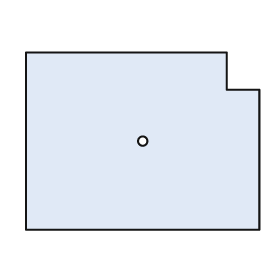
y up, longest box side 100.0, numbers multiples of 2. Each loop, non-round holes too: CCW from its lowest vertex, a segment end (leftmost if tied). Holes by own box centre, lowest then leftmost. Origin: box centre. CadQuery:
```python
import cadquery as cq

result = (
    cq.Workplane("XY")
    .moveTo(-50.0, -38.0)
    .lineTo(50.0, -38.0)
    .lineTo(50.0, 22.0)
    .lineTo(36.0, 22.0)
    .lineTo(36.0, 38.0)
    .lineTo(-50.0, 38.0)
    .close()
    .moveTo(0.0, 0.0)
    .circle(2.0)
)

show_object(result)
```